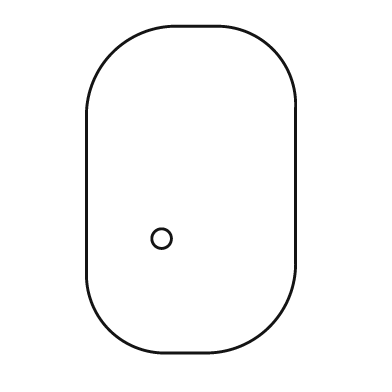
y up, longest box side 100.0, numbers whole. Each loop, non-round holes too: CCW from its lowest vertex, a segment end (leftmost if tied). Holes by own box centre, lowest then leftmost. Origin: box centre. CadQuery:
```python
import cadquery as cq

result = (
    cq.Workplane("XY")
    .moveTo(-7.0, -50.0)
    .lineTo(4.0, -50.0)
    .threePointArc((24.0, -42.0), (32.0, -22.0))
    .lineTo(32.0, 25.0)
    .threePointArc((25.0, 43.0), (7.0, 50.0))
    .lineTo(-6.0, 50.0)
    .threePointArc((-24.0, 42.0), (-32.0, 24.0))
    .lineTo(-32.0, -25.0)
    .threePointArc((-25.0, -43.0), (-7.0, -50.0))
    .close()
    .moveTo(-9.0, -15.0)
    .circle(3.0)
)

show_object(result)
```